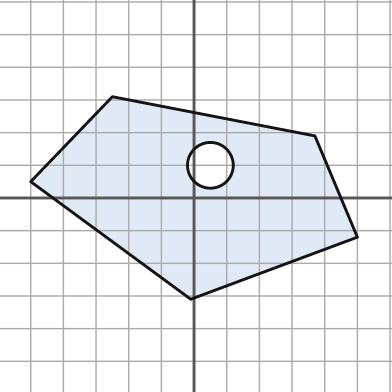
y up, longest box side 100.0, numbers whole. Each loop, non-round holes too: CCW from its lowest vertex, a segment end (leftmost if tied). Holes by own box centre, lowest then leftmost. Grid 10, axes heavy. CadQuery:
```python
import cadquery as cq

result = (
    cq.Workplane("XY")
    .moveTo(-1.0, -31.0)
    .lineTo(50.0, -12.0)
    .lineTo(37.0, 19.0)
    .lineTo(-25.0, 31.0)
    .lineTo(-50.0, 5.0)
    .close()
    .moveTo(5.0, 10.0)
    .circle(7.0)
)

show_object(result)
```